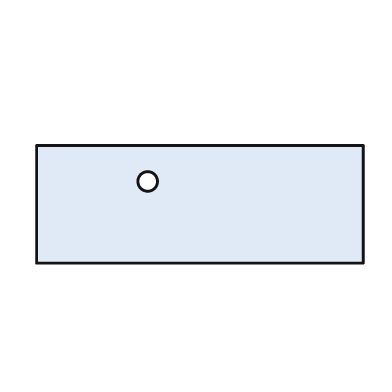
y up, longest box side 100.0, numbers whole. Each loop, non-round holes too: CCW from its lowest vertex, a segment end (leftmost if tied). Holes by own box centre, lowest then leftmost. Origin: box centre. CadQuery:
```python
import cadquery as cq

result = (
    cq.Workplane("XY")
    .moveTo(-50.0, -18.0)
    .lineTo(50.0, -18.0)
    .lineTo(50.0, 18.0)
    .lineTo(-50.0, 18.0)
    .close()
    .moveTo(-16.0, 7.0)
    .circle(3.0)
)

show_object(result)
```